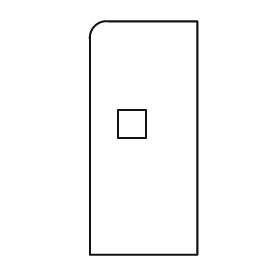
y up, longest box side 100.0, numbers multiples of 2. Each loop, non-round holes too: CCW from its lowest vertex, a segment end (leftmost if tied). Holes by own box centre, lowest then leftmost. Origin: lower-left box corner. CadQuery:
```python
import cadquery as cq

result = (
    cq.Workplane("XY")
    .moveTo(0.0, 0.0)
    .lineTo(46.0, 0.0)
    .lineTo(46.0, 100.0)
    .lineTo(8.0, 100.0)
    .threePointArc((2.0, 98.0), (0.0, 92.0))
    .close()
    .moveTo(12.0, 50.0)
    .lineTo(24.0, 50.0)
    .lineTo(24.0, 62.0)
    .lineTo(12.0, 62.0)
    .close()
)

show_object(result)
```